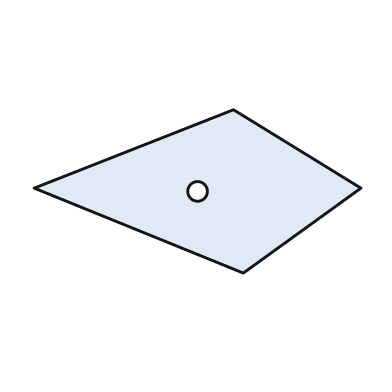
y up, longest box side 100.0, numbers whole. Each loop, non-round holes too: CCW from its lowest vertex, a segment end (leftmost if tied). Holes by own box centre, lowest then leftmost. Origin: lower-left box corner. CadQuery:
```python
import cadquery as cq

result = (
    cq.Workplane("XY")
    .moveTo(64.0, 0.0)
    .lineTo(100.0, 26.0)
    .lineTo(61.0, 50.0)
    .lineTo(0.0, 26.0)
    .close()
    .moveTo(50.0, 25.0)
    .circle(3.0)
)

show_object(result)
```